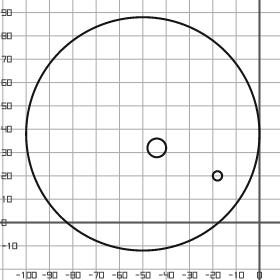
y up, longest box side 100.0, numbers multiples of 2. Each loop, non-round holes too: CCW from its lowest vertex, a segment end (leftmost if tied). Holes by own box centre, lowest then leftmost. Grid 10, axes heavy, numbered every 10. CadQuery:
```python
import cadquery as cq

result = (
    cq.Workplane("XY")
    .moveTo(-50.0, 38.0)
    .circle(50.0)
    .moveTo(-18.0, 20.0)
    .circle(2.0)
    .moveTo(-44.0, 32.0)
    .circle(4.0)
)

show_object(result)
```